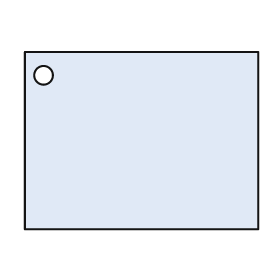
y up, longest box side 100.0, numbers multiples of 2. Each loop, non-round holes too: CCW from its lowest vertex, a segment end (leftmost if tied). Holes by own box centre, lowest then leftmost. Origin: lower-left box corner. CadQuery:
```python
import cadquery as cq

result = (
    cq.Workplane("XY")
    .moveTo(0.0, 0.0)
    .lineTo(100.0, 0.0)
    .lineTo(100.0, 76.0)
    .lineTo(0.0, 76.0)
    .close()
    .moveTo(8.0, 66.0)
    .circle(4.0)
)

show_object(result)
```